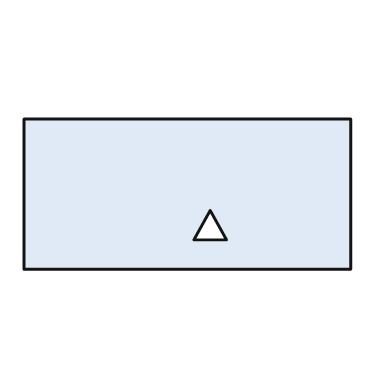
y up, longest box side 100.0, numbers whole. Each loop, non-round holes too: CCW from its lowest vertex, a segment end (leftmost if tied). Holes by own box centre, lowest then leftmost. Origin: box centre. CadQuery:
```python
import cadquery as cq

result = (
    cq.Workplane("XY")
    .moveTo(-50.0, -23.0)
    .lineTo(50.0, -23.0)
    .lineTo(50.0, 23.0)
    .lineTo(-50.0, 23.0)
    .close()
    .moveTo(2.0, -14.0)
    .lineTo(12.0, -14.0)
    .lineTo(7.0, -5.0)
    .close()
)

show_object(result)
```